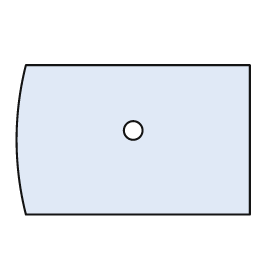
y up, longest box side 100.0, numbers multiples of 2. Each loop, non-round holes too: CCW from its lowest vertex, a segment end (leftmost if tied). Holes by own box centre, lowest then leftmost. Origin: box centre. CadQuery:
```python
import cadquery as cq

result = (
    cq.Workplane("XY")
    .moveTo(-46.0, -32.0)
    .lineTo(50.0, -32.0)
    .lineTo(50.0, 32.0)
    .lineTo(-46.0, 32.0)
    .threePointArc((-50.0, 0.0), (-46.0, -32.0))
    .close()
    .moveTo(0.0, 4.0)
    .circle(4.0)
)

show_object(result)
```